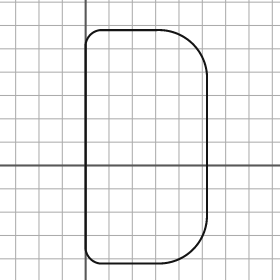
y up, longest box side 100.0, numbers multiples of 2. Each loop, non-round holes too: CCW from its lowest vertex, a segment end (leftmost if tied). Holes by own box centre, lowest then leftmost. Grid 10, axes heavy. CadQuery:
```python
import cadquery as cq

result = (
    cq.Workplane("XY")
    .moveTo(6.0, -42.0)
    .lineTo(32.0, -42.0)
    .threePointArc((46.0, -36.0), (52.0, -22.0))
    .lineTo(52.0, 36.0)
    .threePointArc((46.0, 52.0), (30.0, 58.0))
    .lineTo(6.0, 58.0)
    .threePointArc((2.0, 56.0), (0.0, 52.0))
    .lineTo(0.0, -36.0)
    .threePointArc((2.0, -40.0), (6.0, -42.0))
    .close()
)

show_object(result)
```